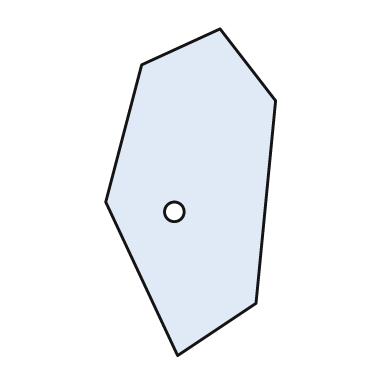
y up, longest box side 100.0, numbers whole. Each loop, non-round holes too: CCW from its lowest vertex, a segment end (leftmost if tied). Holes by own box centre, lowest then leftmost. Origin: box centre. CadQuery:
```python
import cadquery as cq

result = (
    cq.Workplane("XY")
    .moveTo(-4.0, -50.0)
    .lineTo(20.0, -34.0)
    .lineTo(26.0, 28.0)
    .lineTo(9.0, 50.0)
    .lineTo(-15.0, 39.0)
    .lineTo(-26.0, -3.0)
    .close()
    .moveTo(-5.0, -6.0)
    .circle(3.0)
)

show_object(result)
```